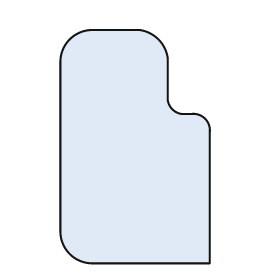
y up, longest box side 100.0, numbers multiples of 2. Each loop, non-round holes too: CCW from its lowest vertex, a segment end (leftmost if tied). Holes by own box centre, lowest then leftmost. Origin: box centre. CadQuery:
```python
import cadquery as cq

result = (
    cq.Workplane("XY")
    .moveTo(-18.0, -50.0)
    .lineTo(32.0, -50.0)
    .lineTo(32.0, 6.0)
    .threePointArc((30.0, 12.0), (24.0, 14.0))
    .lineTo(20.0, 14.0)
    .threePointArc((16.0, 16.0), (14.0, 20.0))
    .lineTo(14.0, 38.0)
    .threePointArc((10.0, 46.0), (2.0, 50.0))
    .lineTo(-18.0, 50.0)
    .threePointArc((-28.0, 46.0), (-32.0, 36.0))
    .lineTo(-32.0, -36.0)
    .threePointArc((-28.0, -46.0), (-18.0, -50.0))
    .close()
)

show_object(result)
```